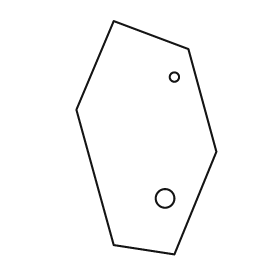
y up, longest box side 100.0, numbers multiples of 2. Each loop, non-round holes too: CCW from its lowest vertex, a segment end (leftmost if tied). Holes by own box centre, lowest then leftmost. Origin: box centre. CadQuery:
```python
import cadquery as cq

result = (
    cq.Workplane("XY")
    .moveTo(12.0, -50.0)
    .lineTo(30.0, -6.0)
    .lineTo(18.0, 38.0)
    .lineTo(-14.0, 50.0)
    .lineTo(-30.0, 12.0)
    .lineTo(-14.0, -46.0)
    .close()
    .moveTo(8.0, -26.0)
    .circle(4.0)
    .moveTo(12.0, 26.0)
    .circle(2.0)
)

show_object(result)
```